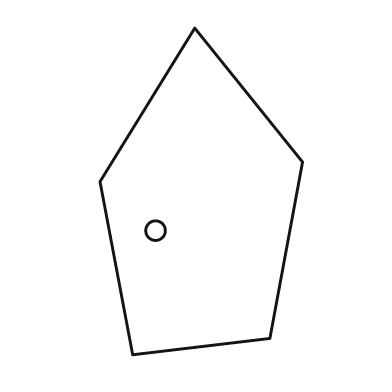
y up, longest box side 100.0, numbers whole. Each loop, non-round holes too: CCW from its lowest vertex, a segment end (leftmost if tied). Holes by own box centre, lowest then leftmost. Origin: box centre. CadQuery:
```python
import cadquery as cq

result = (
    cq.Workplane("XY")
    .moveTo(-21.0, -50.0)
    .lineTo(21.0, -45.0)
    .lineTo(31.0, 9.0)
    .lineTo(-2.0, 50.0)
    .lineTo(-31.0, 3.0)
    .close()
    .moveTo(-14.0, -12.0)
    .circle(3.0)
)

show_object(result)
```